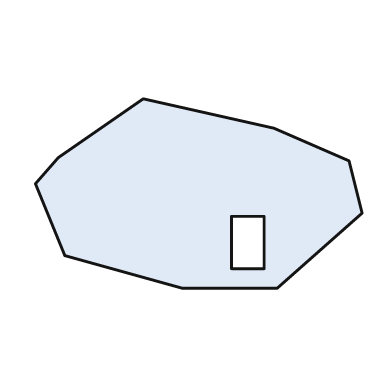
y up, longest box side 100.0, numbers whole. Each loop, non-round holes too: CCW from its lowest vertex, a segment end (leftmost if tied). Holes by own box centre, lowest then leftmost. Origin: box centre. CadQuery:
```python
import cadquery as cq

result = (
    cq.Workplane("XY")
    .moveTo(-5.0, -29.0)
    .lineTo(24.0, -29.0)
    .lineTo(50.0, -6.0)
    .lineTo(46.0, 10.0)
    .lineTo(23.0, 20.0)
    .lineTo(-17.0, 29.0)
    .lineTo(-43.0, 11.0)
    .lineTo(-50.0, 3.0)
    .lineTo(-41.0, -19.0)
    .close()
    .moveTo(10.0, -23.0)
    .lineTo(20.0, -23.0)
    .lineTo(20.0, -7.0)
    .lineTo(10.0, -7.0)
    .close()
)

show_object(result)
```